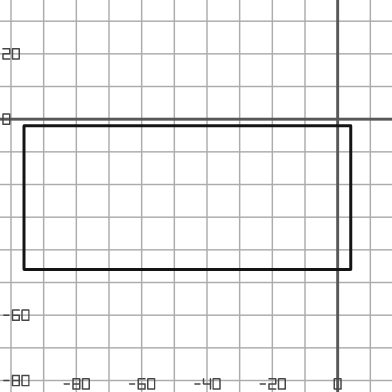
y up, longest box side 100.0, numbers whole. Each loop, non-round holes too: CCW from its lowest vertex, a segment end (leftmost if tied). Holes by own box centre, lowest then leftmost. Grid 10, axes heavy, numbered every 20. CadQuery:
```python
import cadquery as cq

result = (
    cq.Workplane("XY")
    .moveTo(-96.0, -46.0)
    .lineTo(4.0, -46.0)
    .lineTo(4.0, -2.0)
    .lineTo(-96.0, -2.0)
    .close()
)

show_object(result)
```